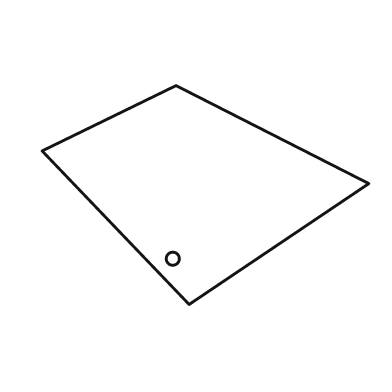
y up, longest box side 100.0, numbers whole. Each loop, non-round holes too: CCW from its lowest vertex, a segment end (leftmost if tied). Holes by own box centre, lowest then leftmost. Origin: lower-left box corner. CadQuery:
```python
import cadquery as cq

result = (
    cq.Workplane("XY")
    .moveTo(45.0, 0.0)
    .lineTo(100.0, 37.0)
    .lineTo(41.0, 67.0)
    .lineTo(0.0, 47.0)
    .close()
    .moveTo(40.0, 14.0)
    .circle(2.0)
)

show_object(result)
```